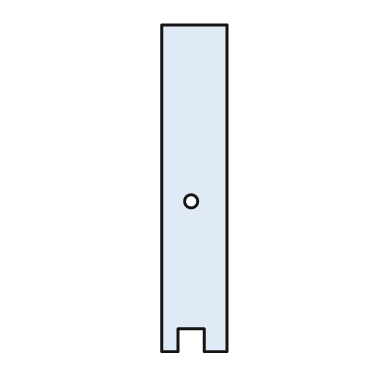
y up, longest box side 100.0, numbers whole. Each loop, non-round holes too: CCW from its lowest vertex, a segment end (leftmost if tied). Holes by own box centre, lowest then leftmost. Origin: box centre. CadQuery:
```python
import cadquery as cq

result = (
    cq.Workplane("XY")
    .moveTo(-10.0, -50.0)
    .lineTo(-5.0, -50.0)
    .lineTo(-5.0, -43.0)
    .lineTo(3.0, -43.0)
    .lineTo(3.0, -50.0)
    .lineTo(10.0, -50.0)
    .lineTo(10.0, 50.0)
    .lineTo(-10.0, 50.0)
    .close()
    .moveTo(-1.0, -4.0)
    .circle(2.0)
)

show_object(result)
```